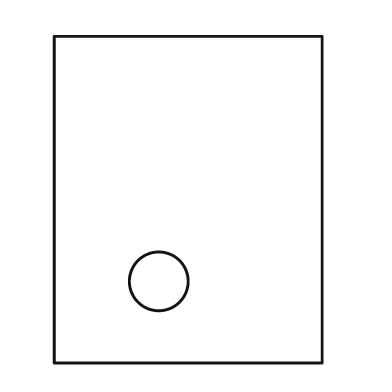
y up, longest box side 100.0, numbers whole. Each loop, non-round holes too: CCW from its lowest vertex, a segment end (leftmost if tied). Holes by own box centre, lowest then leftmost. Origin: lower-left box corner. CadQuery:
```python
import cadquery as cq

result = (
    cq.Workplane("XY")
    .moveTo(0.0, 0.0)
    .lineTo(82.0, 0.0)
    .lineTo(82.0, 100.0)
    .lineTo(0.0, 100.0)
    .close()
    .moveTo(32.0, 25.0)
    .circle(9.0)
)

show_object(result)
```